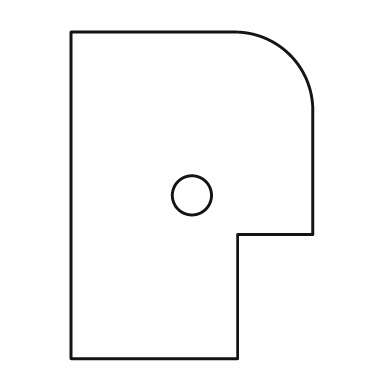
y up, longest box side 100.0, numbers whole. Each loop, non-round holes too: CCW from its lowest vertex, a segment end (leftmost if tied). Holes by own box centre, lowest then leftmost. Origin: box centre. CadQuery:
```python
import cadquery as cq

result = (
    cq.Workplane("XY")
    .moveTo(-37.0, -50.0)
    .lineTo(14.0, -50.0)
    .lineTo(14.0, -12.0)
    .lineTo(37.0, -12.0)
    .lineTo(37.0, 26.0)
    .threePointArc((30.0, 43.0), (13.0, 50.0))
    .lineTo(-37.0, 50.0)
    .close()
    .moveTo(0.0, 0.0)
    .circle(6.0)
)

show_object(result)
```